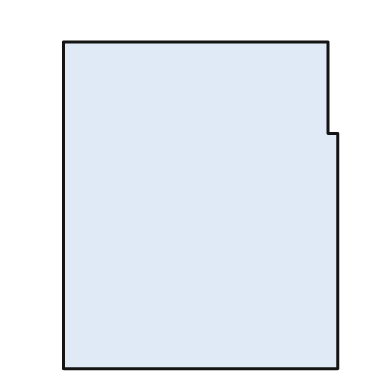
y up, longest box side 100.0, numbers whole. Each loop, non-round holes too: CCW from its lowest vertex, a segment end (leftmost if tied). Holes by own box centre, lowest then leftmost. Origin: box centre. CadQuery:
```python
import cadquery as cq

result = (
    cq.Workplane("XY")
    .moveTo(-42.0, -50.0)
    .lineTo(42.0, -50.0)
    .lineTo(42.0, 22.0)
    .lineTo(39.0, 22.0)
    .lineTo(39.0, 50.0)
    .lineTo(-42.0, 50.0)
    .close()
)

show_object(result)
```